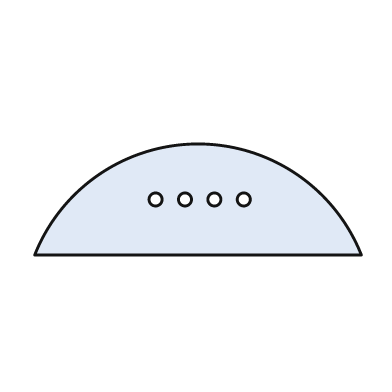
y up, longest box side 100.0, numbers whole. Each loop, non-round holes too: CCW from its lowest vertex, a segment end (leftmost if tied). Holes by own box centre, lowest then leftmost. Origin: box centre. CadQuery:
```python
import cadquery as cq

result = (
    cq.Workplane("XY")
    .moveTo(-50.0, -17.0)
    .lineTo(50.0, -17.0)
    .threePointArc((0.0, 17.0), (-50.0, -17.0))
    .close()
    .moveTo(-13.0, 0.0)
    .circle(2.0)
    .moveTo(-4.0, 0.0)
    .circle(2.0)
    .moveTo(5.0, 0.0)
    .circle(2.0)
    .moveTo(14.0, 0.0)
    .circle(2.0)
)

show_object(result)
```